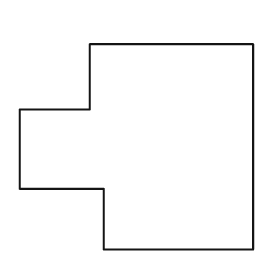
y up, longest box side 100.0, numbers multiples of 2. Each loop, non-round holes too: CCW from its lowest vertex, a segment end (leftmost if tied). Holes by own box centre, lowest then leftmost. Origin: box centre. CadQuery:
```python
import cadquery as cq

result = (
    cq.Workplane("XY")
    .moveTo(-14.0, -44.0)
    .lineTo(50.0, -44.0)
    .lineTo(50.0, 44.0)
    .lineTo(-20.0, 44.0)
    .lineTo(-20.0, 16.0)
    .lineTo(-50.0, 16.0)
    .lineTo(-50.0, -18.0)
    .lineTo(-14.0, -18.0)
    .close()
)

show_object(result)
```